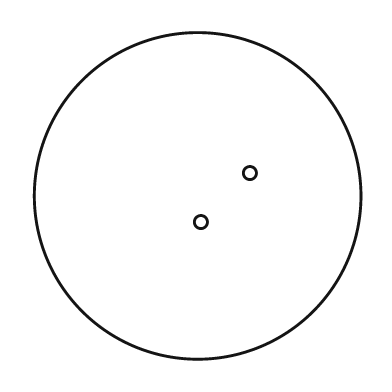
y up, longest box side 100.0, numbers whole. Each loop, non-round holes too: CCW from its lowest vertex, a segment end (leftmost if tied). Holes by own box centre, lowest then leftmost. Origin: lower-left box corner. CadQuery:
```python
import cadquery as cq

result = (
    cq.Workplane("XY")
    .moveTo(50.0, 50.0)
    .circle(50.0)
    .moveTo(51.0, 42.0)
    .circle(2.0)
    .moveTo(66.0, 57.0)
    .circle(2.0)
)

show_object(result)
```